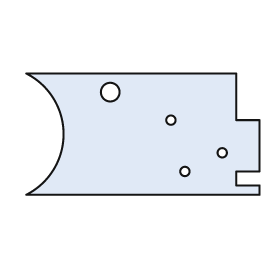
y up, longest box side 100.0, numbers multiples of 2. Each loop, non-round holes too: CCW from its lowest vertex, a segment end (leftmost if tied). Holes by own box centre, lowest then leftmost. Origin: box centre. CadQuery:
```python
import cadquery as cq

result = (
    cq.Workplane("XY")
    .moveTo(-50.0, -26.0)
    .lineTo(50.0, -26.0)
    .lineTo(50.0, -22.0)
    .lineTo(40.0, -22.0)
    .lineTo(40.0, -16.0)
    .lineTo(50.0, -16.0)
    .lineTo(50.0, 6.0)
    .lineTo(40.0, 6.0)
    .lineTo(40.0, 26.0)
    .lineTo(-50.0, 26.0)
    .threePointArc((-34.0, 0.0), (-50.0, -26.0))
    .close()
    .moveTo(18.0, -16.0)
    .circle(2.0)
    .moveTo(34.0, -8.0)
    .circle(2.0)
    .moveTo(12.0, 6.0)
    .circle(2.0)
    .moveTo(-14.0, 18.0)
    .circle(4.0)
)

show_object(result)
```